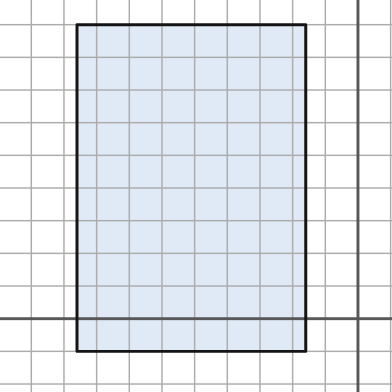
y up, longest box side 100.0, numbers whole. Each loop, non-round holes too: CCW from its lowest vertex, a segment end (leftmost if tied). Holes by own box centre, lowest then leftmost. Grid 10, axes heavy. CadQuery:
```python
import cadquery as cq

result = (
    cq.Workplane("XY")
    .moveTo(-86.0, -10.0)
    .lineTo(-16.0, -10.0)
    .lineTo(-16.0, 90.0)
    .lineTo(-86.0, 90.0)
    .close()
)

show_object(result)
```